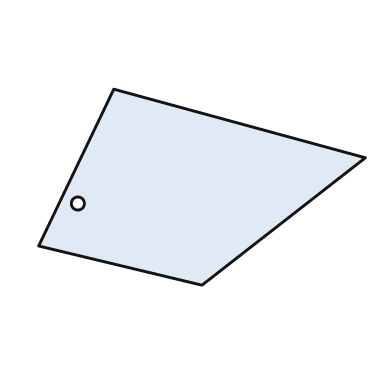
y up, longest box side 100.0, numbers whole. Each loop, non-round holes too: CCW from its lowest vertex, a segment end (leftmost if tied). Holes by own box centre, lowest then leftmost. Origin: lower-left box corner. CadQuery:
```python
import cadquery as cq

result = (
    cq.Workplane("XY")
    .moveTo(50.0, 0.0)
    .lineTo(100.0, 39.0)
    .lineTo(23.0, 60.0)
    .lineTo(0.0, 12.0)
    .close()
    .moveTo(12.0, 25.0)
    .circle(2.0)
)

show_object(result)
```